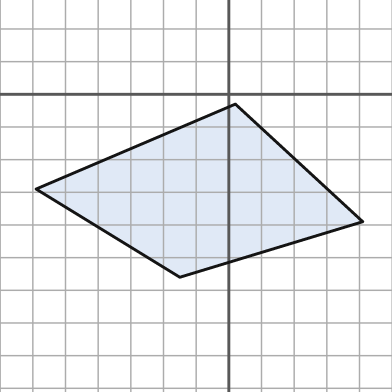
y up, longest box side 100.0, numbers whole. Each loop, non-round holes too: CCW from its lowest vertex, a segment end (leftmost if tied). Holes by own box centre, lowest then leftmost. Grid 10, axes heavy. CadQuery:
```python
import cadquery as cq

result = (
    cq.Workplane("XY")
    .moveTo(-15.0, -56.0)
    .lineTo(41.0, -39.0)
    .lineTo(2.0, -3.0)
    .lineTo(-59.0, -29.0)
    .close()
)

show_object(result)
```